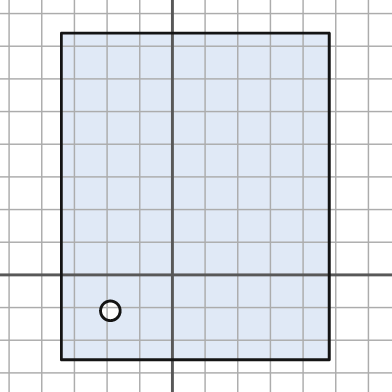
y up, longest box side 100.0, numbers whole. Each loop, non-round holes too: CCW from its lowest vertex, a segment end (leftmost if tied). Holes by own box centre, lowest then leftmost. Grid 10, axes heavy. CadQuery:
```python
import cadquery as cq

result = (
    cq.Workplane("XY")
    .moveTo(-34.0, -26.0)
    .lineTo(48.0, -26.0)
    .lineTo(48.0, 74.0)
    .lineTo(-34.0, 74.0)
    .close()
    .moveTo(-19.0, -11.0)
    .circle(3.0)
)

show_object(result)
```